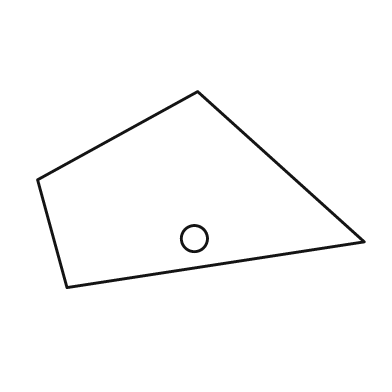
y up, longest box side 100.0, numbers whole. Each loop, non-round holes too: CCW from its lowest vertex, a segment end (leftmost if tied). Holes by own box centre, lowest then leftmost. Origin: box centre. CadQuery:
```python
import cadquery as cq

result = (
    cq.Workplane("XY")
    .moveTo(-41.0, -30.0)
    .lineTo(50.0, -16.0)
    .lineTo(-1.0, 30.0)
    .lineTo(-50.0, 3.0)
    .close()
    .moveTo(-2.0, -15.0)
    .circle(4.0)
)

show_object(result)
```